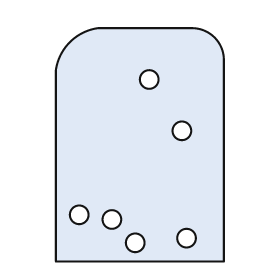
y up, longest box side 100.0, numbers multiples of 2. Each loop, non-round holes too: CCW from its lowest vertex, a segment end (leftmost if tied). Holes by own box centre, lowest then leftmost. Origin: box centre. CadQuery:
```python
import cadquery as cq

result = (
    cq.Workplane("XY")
    .moveTo(-36.0, -50.0)
    .lineTo(36.0, -50.0)
    .lineTo(36.0, 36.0)
    .threePointArc((32.0, 46.0), (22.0, 50.0))
    .lineTo(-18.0, 50.0)
    .threePointArc((-30.0, 44.0), (-36.0, 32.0))
    .close()
    .moveTo(-2.0, -42.0)
    .circle(4.0)
    .moveTo(20.0, -40.0)
    .circle(4.0)
    .moveTo(-12.0, -32.0)
    .circle(4.0)
    .moveTo(-26.0, -30.0)
    .circle(4.0)
    .moveTo(18.0, 6.0)
    .circle(4.0)
    .moveTo(4.0, 28.0)
    .circle(4.0)
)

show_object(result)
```